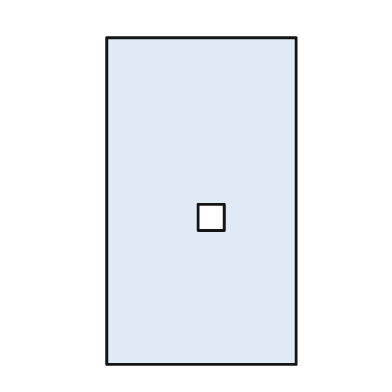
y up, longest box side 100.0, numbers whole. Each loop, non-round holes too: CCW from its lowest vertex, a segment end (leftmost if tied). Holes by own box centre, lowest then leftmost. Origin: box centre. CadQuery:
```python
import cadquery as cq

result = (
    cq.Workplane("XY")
    .moveTo(-29.0, -50.0)
    .lineTo(29.0, -50.0)
    .lineTo(29.0, 50.0)
    .lineTo(-29.0, 50.0)
    .close()
    .moveTo(-1.0, -9.0)
    .lineTo(7.0, -9.0)
    .lineTo(7.0, -1.0)
    .lineTo(-1.0, -1.0)
    .close()
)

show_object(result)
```